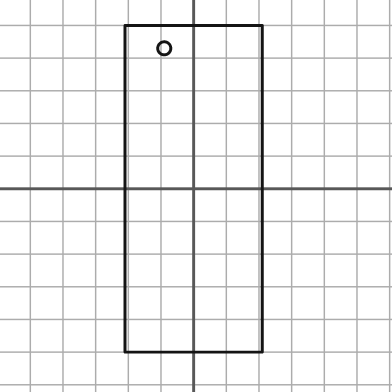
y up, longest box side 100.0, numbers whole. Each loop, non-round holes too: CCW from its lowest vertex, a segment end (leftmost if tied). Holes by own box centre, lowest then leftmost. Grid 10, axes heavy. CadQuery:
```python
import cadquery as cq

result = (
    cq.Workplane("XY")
    .moveTo(-21.0, -50.0)
    .lineTo(21.0, -50.0)
    .lineTo(21.0, 50.0)
    .lineTo(-21.0, 50.0)
    .close()
    .moveTo(-9.0, 43.0)
    .circle(2.0)
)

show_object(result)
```